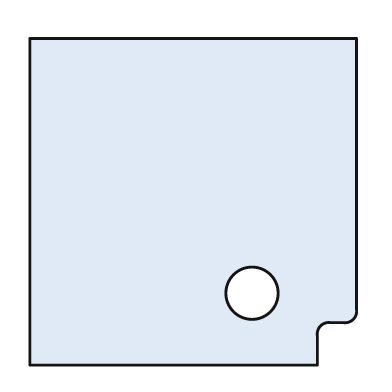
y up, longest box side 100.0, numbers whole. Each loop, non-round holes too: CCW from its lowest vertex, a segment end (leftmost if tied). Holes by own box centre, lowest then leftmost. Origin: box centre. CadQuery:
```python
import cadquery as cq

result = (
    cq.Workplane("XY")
    .moveTo(-50.0, -50.0)
    .lineTo(38.0, -50.0)
    .lineTo(38.0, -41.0)
    .threePointArc((39.0, -38.0), (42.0, -37.0))
    .lineTo(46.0, -37.0)
    .threePointArc((49.0, -36.0), (50.0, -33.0))
    .lineTo(50.0, 50.0)
    .lineTo(-50.0, 50.0)
    .close()
    .moveTo(18.0, -28.0)
    .circle(8.0)
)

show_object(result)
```